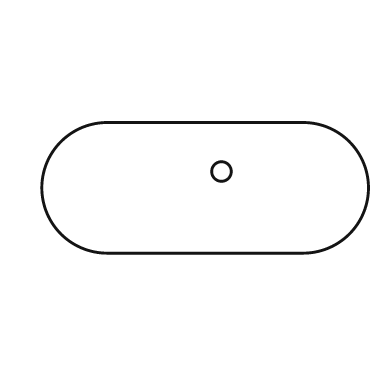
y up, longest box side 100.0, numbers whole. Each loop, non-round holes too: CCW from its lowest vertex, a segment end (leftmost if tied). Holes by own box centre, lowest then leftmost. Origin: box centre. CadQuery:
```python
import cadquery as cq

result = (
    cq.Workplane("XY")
    .moveTo(-30.0, -20.0)
    .lineTo(30.0, -20.0)
    .threePointArc((50.0, 0.0), (30.0, 20.0))
    .lineTo(-30.0, 20.0)
    .threePointArc((-50.0, 0.0), (-30.0, -20.0))
    .close()
    .moveTo(5.0, 5.0)
    .circle(3.0)
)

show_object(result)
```